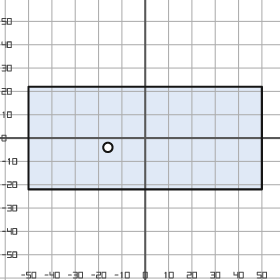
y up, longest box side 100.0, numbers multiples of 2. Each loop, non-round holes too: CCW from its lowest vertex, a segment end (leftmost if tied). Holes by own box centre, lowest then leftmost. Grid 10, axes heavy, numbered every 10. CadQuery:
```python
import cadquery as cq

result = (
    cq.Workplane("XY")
    .moveTo(-50.0, -22.0)
    .lineTo(50.0, -22.0)
    .lineTo(50.0, 22.0)
    .lineTo(-50.0, 22.0)
    .close()
    .moveTo(-16.0, -4.0)
    .circle(2.0)
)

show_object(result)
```